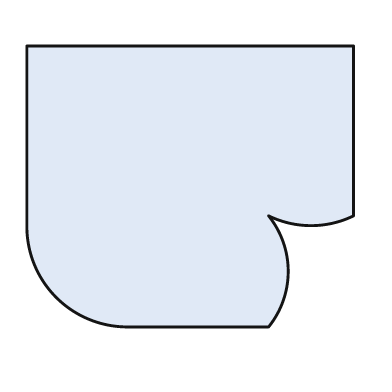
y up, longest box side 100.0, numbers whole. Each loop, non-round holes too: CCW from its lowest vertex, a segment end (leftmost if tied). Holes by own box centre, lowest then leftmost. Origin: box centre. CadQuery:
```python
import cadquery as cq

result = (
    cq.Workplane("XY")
    .moveTo(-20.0, -43.0)
    .lineTo(24.0, -43.0)
    .threePointArc((30.0, -26.0), (24.0, -9.0))
    .threePointArc((37.0, -12.0), (50.0, -9.0))
    .lineTo(50.0, 43.0)
    .lineTo(-50.0, 43.0)
    .lineTo(-50.0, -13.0)
    .threePointArc((-41.0, -34.0), (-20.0, -43.0))
    .close()
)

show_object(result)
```